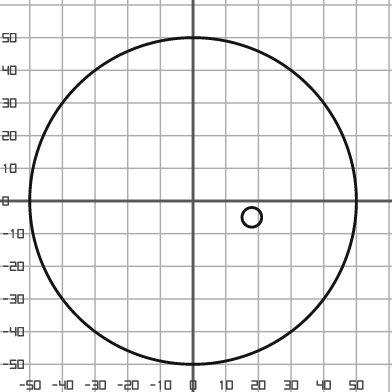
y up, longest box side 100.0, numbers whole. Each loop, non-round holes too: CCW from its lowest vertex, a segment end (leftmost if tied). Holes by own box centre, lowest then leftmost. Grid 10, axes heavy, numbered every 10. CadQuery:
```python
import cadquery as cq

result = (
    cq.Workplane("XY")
    .moveTo(0.0, 0.0)
    .circle(50.0)
    .moveTo(18.0, -5.0)
    .circle(3.0)
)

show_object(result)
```